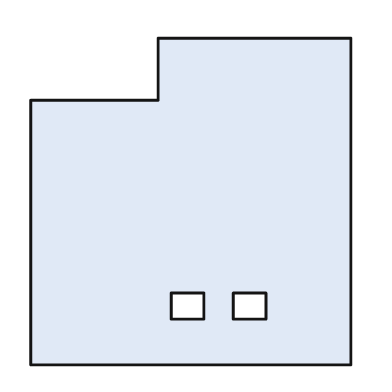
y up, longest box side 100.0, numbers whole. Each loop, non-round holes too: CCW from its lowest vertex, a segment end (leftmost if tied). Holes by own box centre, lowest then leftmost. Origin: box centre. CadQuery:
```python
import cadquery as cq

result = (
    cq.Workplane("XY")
    .moveTo(-49.0, -50.0)
    .lineTo(49.0, -50.0)
    .lineTo(49.0, 50.0)
    .lineTo(-10.0, 50.0)
    .lineTo(-10.0, 31.0)
    .lineTo(-49.0, 31.0)
    .close()
    .moveTo(-6.0, -36.0)
    .lineTo(4.0, -36.0)
    .lineTo(4.0, -28.0)
    .lineTo(-6.0, -28.0)
    .close()
    .moveTo(13.0, -36.0)
    .lineTo(23.0, -36.0)
    .lineTo(23.0, -28.0)
    .lineTo(13.0, -28.0)
    .close()
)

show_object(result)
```